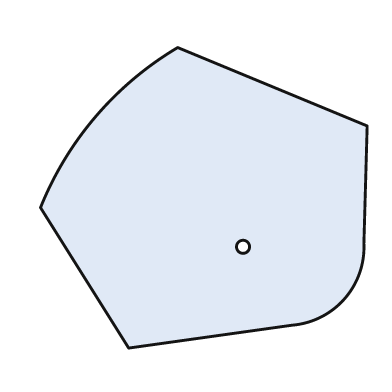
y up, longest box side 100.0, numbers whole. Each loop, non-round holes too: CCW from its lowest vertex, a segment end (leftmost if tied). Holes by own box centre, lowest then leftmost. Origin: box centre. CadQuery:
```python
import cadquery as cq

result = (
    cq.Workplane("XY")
    .moveTo(-23.0, -46.0)
    .lineTo(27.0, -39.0)
    .threePointArc((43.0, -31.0), (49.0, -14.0))
    .lineTo(50.0, 22.0)
    .lineTo(-8.0, 46.0)
    .threePointArc((-33.0, 25.0), (-50.0, -3.0))
    .close()
    .moveTo(12.0, -15.0)
    .circle(2.0)
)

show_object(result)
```